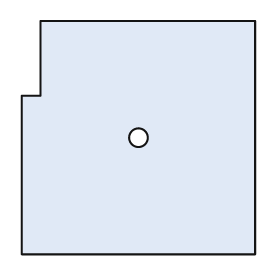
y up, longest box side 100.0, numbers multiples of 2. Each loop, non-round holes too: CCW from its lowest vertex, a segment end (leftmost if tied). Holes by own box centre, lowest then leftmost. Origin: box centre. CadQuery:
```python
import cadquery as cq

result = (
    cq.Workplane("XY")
    .moveTo(-50.0, -50.0)
    .lineTo(50.0, -50.0)
    .lineTo(50.0, 50.0)
    .lineTo(-42.0, 50.0)
    .lineTo(-42.0, 18.0)
    .lineTo(-50.0, 18.0)
    .close()
    .moveTo(0.0, 0.0)
    .circle(4.0)
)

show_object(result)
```